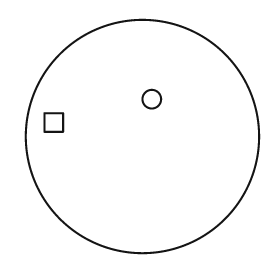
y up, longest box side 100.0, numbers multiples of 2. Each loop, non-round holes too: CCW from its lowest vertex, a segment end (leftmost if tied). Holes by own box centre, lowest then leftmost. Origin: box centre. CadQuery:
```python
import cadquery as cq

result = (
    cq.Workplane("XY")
    .moveTo(0.0, 0.0)
    .circle(50.0)
    .moveTo(-42.0, 2.0)
    .lineTo(-34.0, 2.0)
    .lineTo(-34.0, 10.0)
    .lineTo(-42.0, 10.0)
    .close()
    .moveTo(4.0, 16.0)
    .circle(4.0)
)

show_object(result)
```